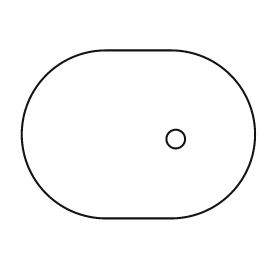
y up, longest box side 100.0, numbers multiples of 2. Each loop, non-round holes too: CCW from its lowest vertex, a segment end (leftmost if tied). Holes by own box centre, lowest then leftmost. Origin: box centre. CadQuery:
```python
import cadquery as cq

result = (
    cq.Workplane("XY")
    .moveTo(-14.0, -36.0)
    .lineTo(14.0, -36.0)
    .threePointArc((50.0, 0.0), (14.0, 36.0))
    .lineTo(-14.0, 36.0)
    .threePointArc((-50.0, 0.0), (-14.0, -36.0))
    .close()
    .moveTo(16.0, -2.0)
    .circle(4.0)
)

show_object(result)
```